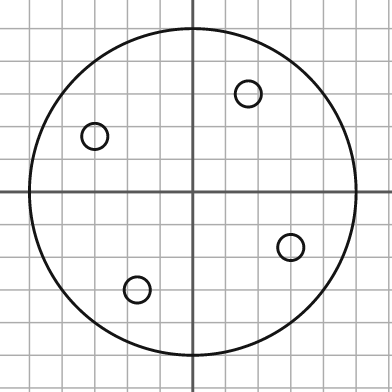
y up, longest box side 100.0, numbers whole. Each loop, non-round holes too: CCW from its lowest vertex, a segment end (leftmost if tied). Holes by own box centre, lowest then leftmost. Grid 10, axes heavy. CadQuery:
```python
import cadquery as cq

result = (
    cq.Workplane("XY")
    .moveTo(0.0, 0.0)
    .circle(50.0)
    .moveTo(-17.0, -30.0)
    .circle(4.0)
    .moveTo(30.0, -17.0)
    .circle(4.0)
    .moveTo(-30.0, 17.0)
    .circle(4.0)
    .moveTo(17.0, 30.0)
    .circle(4.0)
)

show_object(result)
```